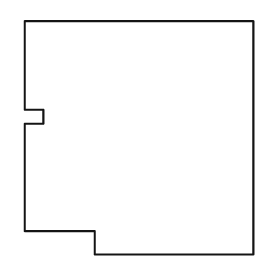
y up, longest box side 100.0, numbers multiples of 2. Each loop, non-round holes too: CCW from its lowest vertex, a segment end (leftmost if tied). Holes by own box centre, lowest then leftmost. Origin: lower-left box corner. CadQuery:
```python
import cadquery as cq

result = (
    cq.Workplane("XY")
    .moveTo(30.0, 0.0)
    .lineTo(98.0, 0.0)
    .lineTo(98.0, 100.0)
    .lineTo(0.0, 100.0)
    .lineTo(0.0, 62.0)
    .lineTo(8.0, 62.0)
    .lineTo(8.0, 56.0)
    .lineTo(0.0, 56.0)
    .lineTo(0.0, 10.0)
    .lineTo(30.0, 10.0)
    .close()
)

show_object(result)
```